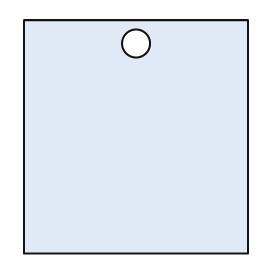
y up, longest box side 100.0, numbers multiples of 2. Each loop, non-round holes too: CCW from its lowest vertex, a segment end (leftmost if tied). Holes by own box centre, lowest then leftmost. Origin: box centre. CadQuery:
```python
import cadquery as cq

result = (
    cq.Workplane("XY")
    .moveTo(-48.0, -50.0)
    .lineTo(48.0, -50.0)
    .lineTo(48.0, 50.0)
    .lineTo(-48.0, 50.0)
    .close()
    .moveTo(0.0, 40.0)
    .circle(6.0)
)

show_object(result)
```